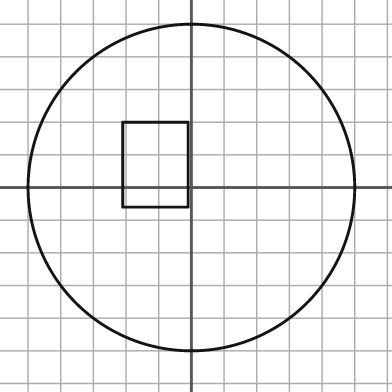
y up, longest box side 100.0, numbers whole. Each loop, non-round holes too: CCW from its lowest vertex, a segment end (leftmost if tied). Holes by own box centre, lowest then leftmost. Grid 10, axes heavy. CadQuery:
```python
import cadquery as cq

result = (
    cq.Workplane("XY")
    .moveTo(0.0, 0.0)
    .circle(50.0)
    .moveTo(-21.0, -6.0)
    .lineTo(-1.0, -6.0)
    .lineTo(-1.0, 20.0)
    .lineTo(-21.0, 20.0)
    .close()
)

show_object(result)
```